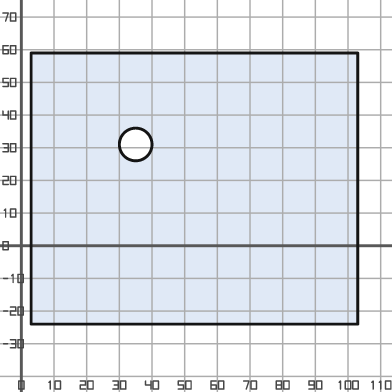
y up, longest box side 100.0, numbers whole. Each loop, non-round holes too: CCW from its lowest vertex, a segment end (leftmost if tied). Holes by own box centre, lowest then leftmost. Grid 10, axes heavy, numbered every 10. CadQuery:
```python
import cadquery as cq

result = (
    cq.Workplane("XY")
    .moveTo(3.0, -24.0)
    .lineTo(103.0, -24.0)
    .lineTo(103.0, 59.0)
    .lineTo(3.0, 59.0)
    .close()
    .moveTo(35.0, 31.0)
    .circle(5.0)
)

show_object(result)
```